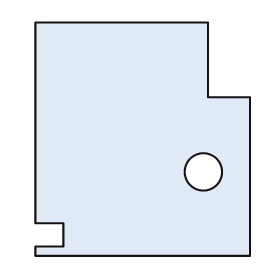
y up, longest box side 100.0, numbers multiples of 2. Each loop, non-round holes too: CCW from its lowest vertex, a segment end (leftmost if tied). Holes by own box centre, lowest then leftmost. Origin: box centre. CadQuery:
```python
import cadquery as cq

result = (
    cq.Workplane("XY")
    .moveTo(-46.0, -50.0)
    .lineTo(46.0, -50.0)
    .lineTo(46.0, 18.0)
    .lineTo(28.0, 18.0)
    .lineTo(28.0, 50.0)
    .lineTo(-46.0, 50.0)
    .lineTo(-46.0, -36.0)
    .lineTo(-34.0, -36.0)
    .lineTo(-34.0, -46.0)
    .lineTo(-46.0, -46.0)
    .close()
    .moveTo(26.0, -14.0)
    .circle(8.0)
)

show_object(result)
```